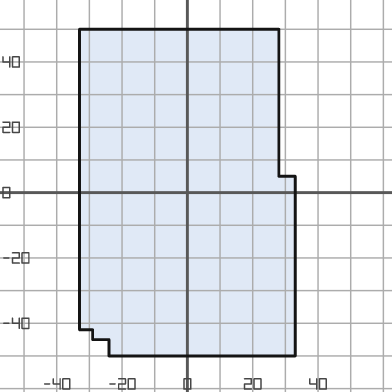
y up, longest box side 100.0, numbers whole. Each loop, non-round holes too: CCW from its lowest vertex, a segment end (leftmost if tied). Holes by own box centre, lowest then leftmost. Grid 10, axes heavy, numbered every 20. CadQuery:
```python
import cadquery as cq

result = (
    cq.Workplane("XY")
    .moveTo(-24.0, -50.0)
    .lineTo(33.0, -50.0)
    .lineTo(33.0, 5.0)
    .lineTo(28.0, 5.0)
    .lineTo(28.0, 50.0)
    .lineTo(-33.0, 50.0)
    .lineTo(-33.0, -42.0)
    .lineTo(-29.0, -42.0)
    .lineTo(-29.0, -45.0)
    .lineTo(-24.0, -45.0)
    .close()
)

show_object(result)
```